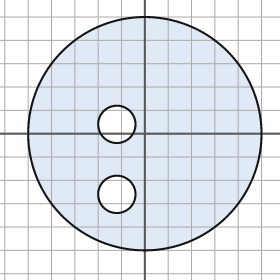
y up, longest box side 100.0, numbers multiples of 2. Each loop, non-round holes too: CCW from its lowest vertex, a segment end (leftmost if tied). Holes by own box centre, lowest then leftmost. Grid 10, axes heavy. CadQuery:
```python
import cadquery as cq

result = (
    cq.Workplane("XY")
    .moveTo(0.0, 0.0)
    .circle(50.0)
    .moveTo(-12.0, -26.0)
    .circle(8.0)
    .moveTo(-12.0, 4.0)
    .circle(8.0)
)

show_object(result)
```